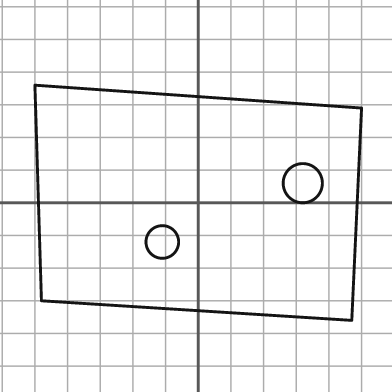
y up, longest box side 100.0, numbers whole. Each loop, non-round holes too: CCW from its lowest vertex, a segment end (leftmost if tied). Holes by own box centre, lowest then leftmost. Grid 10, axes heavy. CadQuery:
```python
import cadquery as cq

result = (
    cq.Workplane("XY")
    .moveTo(47.0, -36.0)
    .lineTo(50.0, 29.0)
    .lineTo(-50.0, 36.0)
    .lineTo(-48.0, -30.0)
    .close()
    .moveTo(-11.0, -12.0)
    .circle(5.0)
    .moveTo(32.0, 6.0)
    .circle(6.0)
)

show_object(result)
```